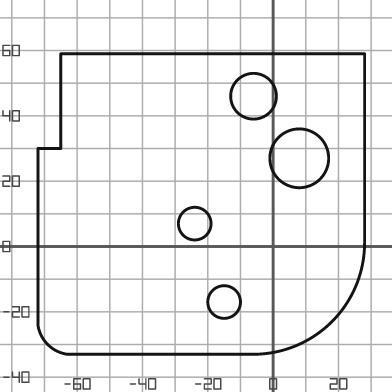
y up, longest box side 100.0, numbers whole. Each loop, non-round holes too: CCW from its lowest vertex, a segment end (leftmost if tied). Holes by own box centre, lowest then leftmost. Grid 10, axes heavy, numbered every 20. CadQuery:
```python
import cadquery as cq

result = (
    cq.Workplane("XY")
    .moveTo(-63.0, -33.0)
    .lineTo(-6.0, -33.0)
    .threePointArc((18.0, -23.0), (28.0, 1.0))
    .lineTo(28.0, 59.0)
    .lineTo(-65.0, 59.0)
    .lineTo(-65.0, 30.0)
    .lineTo(-72.0, 30.0)
    .lineTo(-72.0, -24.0)
    .threePointArc((-69.0, -30.0), (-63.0, -33.0))
    .close()
    .moveTo(-15.0, -17.0)
    .circle(5.0)
    .moveTo(-24.0, 7.0)
    .circle(5.0)
    .moveTo(8.0, 27.0)
    .circle(9.0)
    .moveTo(-6.0, 46.0)
    .circle(7.0)
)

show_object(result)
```